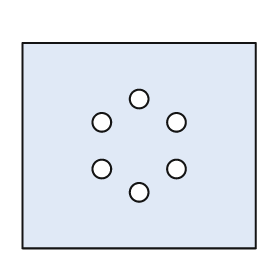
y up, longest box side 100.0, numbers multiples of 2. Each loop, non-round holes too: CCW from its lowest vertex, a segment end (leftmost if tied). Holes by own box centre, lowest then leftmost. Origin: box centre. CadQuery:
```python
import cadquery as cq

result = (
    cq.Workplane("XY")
    .moveTo(-50.0, -44.0)
    .lineTo(50.0, -44.0)
    .lineTo(50.0, 44.0)
    .lineTo(-50.0, 44.0)
    .close()
    .moveTo(0.0, -20.0)
    .circle(4.0)
    .moveTo(-16.0, -10.0)
    .circle(4.0)
    .moveTo(16.0, -10.0)
    .circle(4.0)
    .moveTo(-16.0, 10.0)
    .circle(4.0)
    .moveTo(16.0, 10.0)
    .circle(4.0)
    .moveTo(0.0, 20.0)
    .circle(4.0)
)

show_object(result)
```